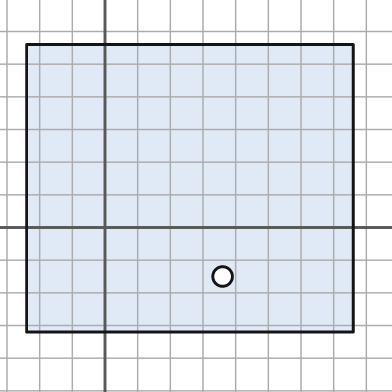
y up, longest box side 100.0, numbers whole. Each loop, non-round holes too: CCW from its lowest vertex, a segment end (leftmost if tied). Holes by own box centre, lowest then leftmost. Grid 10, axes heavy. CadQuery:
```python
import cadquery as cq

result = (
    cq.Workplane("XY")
    .moveTo(-24.0, -32.0)
    .lineTo(76.0, -32.0)
    .lineTo(76.0, 56.0)
    .lineTo(-24.0, 56.0)
    .close()
    .moveTo(36.0, -15.0)
    .circle(3.0)
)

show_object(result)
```